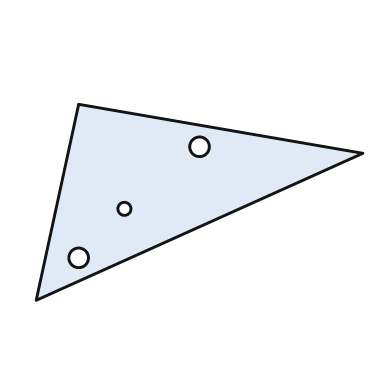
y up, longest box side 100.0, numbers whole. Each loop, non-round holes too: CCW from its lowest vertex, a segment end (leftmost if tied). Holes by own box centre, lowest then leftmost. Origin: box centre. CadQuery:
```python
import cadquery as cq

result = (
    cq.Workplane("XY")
    .moveTo(-50.0, -30.0)
    .lineTo(50.0, 15.0)
    .lineTo(-37.0, 30.0)
    .close()
    .moveTo(-37.0, -17.0)
    .circle(3.0)
    .moveTo(-23.0, -2.0)
    .circle(2.0)
    .moveTo(0.0, 17.0)
    .circle(3.0)
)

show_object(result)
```